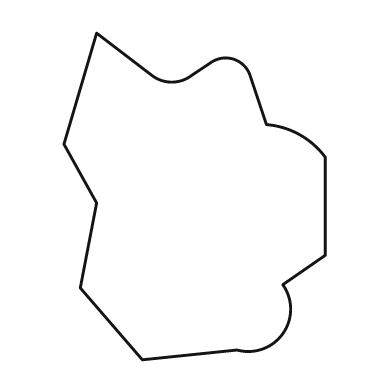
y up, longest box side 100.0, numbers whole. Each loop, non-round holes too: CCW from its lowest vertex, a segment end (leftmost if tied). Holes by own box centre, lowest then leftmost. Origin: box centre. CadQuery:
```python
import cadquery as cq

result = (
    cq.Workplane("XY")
    .moveTo(-16.0, -50.0)
    .lineTo(13.0, -47.0)
    .threePointArc((27.0, -42.0), (27.0, -27.0))
    .lineTo(40.0, -18.0)
    .lineTo(40.0, 12.0)
    .threePointArc((32.0, 19.0), (22.0, 22.0))
    .lineTo(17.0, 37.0)
    .threePointArc((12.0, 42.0), (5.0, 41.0))
    .lineTo(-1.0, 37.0)
    .threePointArc((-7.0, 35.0), (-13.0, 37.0))
    .lineTo(-30.0, 50.0)
    .lineTo(-40.0, 16.0)
    .lineTo(-30.0, -2.0)
    .lineTo(-35.0, -28.0)
    .close()
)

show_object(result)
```